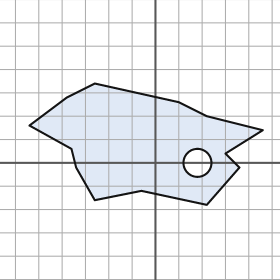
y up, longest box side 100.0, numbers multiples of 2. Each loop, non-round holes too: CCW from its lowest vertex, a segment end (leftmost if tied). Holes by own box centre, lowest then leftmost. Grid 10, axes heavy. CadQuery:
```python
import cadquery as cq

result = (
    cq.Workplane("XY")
    .moveTo(22.0, -18.0)
    .lineTo(36.0, -2.0)
    .lineTo(30.0, 4.0)
    .lineTo(46.0, 14.0)
    .lineTo(22.0, 20.0)
    .lineTo(10.0, 26.0)
    .lineTo(-26.0, 34.0)
    .lineTo(-38.0, 28.0)
    .lineTo(-54.0, 16.0)
    .lineTo(-36.0, 6.0)
    .lineTo(-34.0, -2.0)
    .lineTo(-26.0, -16.0)
    .lineTo(-6.0, -12.0)
    .close()
    .moveTo(18.0, 0.0)
    .circle(6.0)
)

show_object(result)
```